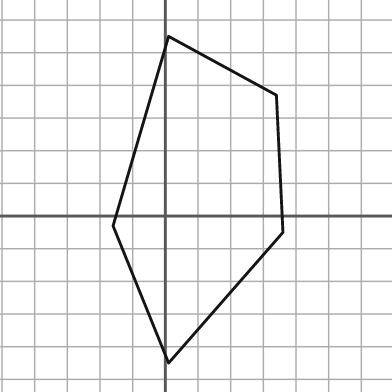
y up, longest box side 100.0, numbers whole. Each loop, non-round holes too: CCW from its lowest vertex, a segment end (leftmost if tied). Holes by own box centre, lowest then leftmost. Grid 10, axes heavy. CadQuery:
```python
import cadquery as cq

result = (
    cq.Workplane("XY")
    .moveTo(1.0, -45.0)
    .lineTo(36.0, -5.0)
    .lineTo(34.0, 37.0)
    .lineTo(1.0, 55.0)
    .lineTo(-16.0, -3.0)
    .close()
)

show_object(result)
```